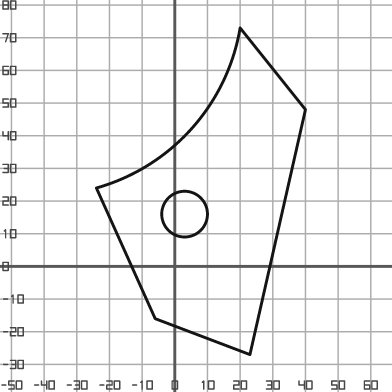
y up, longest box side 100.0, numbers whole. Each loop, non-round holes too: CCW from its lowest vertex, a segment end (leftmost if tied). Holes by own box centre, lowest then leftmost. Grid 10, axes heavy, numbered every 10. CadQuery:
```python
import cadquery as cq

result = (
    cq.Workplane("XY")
    .moveTo(23.0, -27.0)
    .lineTo(40.0, 48.0)
    .lineTo(20.0, 73.0)
    .threePointArc((5.0, 42.0), (-24.0, 24.0))
    .lineTo(-6.0, -16.0)
    .close()
    .moveTo(3.0, 16.0)
    .circle(7.0)
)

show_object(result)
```